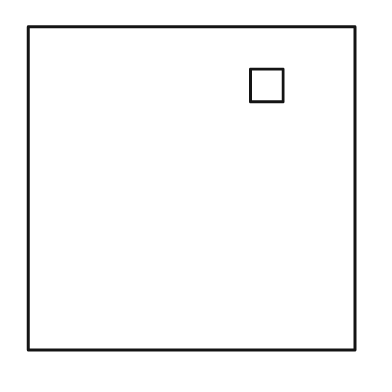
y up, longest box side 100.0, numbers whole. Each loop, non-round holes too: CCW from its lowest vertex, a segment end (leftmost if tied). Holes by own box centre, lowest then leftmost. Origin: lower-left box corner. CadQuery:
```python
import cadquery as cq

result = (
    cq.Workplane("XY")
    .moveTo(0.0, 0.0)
    .lineTo(100.0, 0.0)
    .lineTo(100.0, 99.0)
    .lineTo(0.0, 99.0)
    .close()
    .moveTo(68.0, 76.0)
    .lineTo(78.0, 76.0)
    .lineTo(78.0, 86.0)
    .lineTo(68.0, 86.0)
    .close()
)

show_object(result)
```